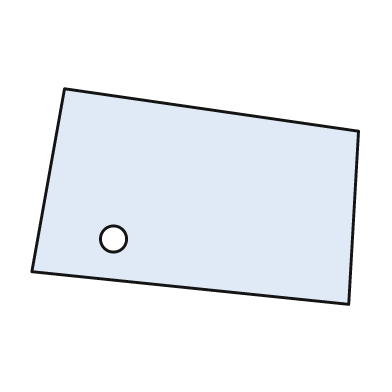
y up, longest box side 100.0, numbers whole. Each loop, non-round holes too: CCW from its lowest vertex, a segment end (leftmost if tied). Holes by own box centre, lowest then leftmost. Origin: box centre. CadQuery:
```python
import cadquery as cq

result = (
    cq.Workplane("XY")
    .moveTo(47.0, -33.0)
    .lineTo(50.0, 20.0)
    .lineTo(-40.0, 33.0)
    .lineTo(-50.0, -23.0)
    .close()
    .moveTo(-25.0, -13.0)
    .circle(4.0)
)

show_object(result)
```